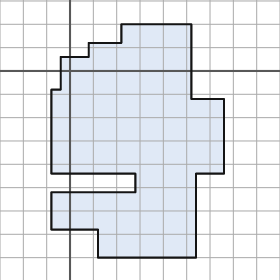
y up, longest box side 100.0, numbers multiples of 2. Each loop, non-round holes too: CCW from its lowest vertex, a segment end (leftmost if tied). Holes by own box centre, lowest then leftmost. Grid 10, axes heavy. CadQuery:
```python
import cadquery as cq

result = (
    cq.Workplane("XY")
    .moveTo(12.0, -80.0)
    .lineTo(54.0, -80.0)
    .lineTo(54.0, -44.0)
    .lineTo(66.0, -44.0)
    .lineTo(66.0, -12.0)
    .lineTo(52.0, -12.0)
    .lineTo(52.0, 20.0)
    .lineTo(22.0, 20.0)
    .lineTo(22.0, 12.0)
    .lineTo(8.0, 12.0)
    .lineTo(8.0, 6.0)
    .lineTo(-4.0, 6.0)
    .lineTo(-4.0, -8.0)
    .lineTo(-8.0, -8.0)
    .lineTo(-8.0, -44.0)
    .lineTo(28.0, -44.0)
    .lineTo(28.0, -52.0)
    .lineTo(-8.0, -52.0)
    .lineTo(-8.0, -68.0)
    .lineTo(12.0, -68.0)
    .close()
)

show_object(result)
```